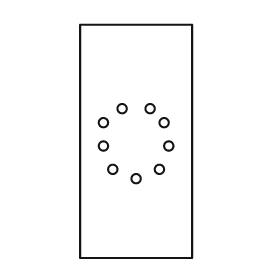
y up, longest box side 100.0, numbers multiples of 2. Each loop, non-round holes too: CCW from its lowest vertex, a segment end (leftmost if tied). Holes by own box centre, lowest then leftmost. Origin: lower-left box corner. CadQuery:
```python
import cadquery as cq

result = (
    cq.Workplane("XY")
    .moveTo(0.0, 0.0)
    .lineTo(48.0, 0.0)
    .lineTo(48.0, 100.0)
    .lineTo(0.0, 100.0)
    .close()
    .moveTo(24.0, 34.0)
    .circle(2.0)
    .moveTo(14.0, 38.0)
    .circle(2.0)
    .moveTo(34.0, 38.0)
    .circle(2.0)
    .moveTo(10.0, 48.0)
    .circle(2.0)
    .moveTo(38.0, 48.0)
    .circle(2.0)
    .moveTo(10.0, 58.0)
    .circle(2.0)
    .moveTo(36.0, 58.0)
    .circle(2.0)
    .moveTo(18.0, 64.0)
    .circle(2.0)
    .moveTo(30.0, 64.0)
    .circle(2.0)
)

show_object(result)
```